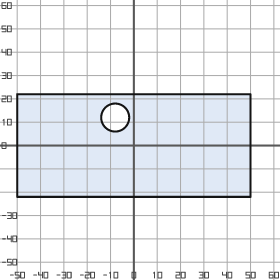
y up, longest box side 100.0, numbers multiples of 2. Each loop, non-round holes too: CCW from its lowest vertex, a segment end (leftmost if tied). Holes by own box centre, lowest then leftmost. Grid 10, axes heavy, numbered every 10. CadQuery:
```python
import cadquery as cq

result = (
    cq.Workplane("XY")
    .moveTo(-50.0, -22.0)
    .lineTo(50.0, -22.0)
    .lineTo(50.0, 22.0)
    .lineTo(-50.0, 22.0)
    .close()
    .moveTo(-8.0, 12.0)
    .circle(6.0)
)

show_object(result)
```